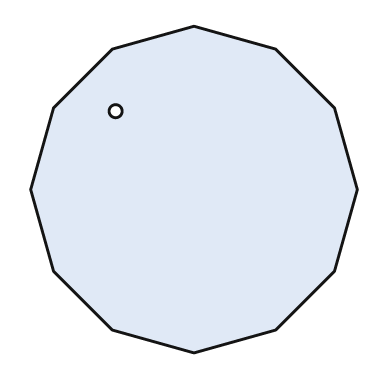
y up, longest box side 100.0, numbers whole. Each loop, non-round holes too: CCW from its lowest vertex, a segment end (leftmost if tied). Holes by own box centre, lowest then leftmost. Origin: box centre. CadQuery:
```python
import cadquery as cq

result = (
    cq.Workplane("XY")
    .moveTo(0.0, -50.0)
    .lineTo(25.0, -43.0)
    .lineTo(43.0, -25.0)
    .lineTo(50.0, 0.0)
    .lineTo(43.0, 25.0)
    .lineTo(25.0, 43.0)
    .lineTo(0.0, 50.0)
    .lineTo(-25.0, 43.0)
    .lineTo(-43.0, 25.0)
    .lineTo(-50.0, 0.0)
    .lineTo(-43.0, -25.0)
    .lineTo(-25.0, -43.0)
    .close()
    .moveTo(-24.0, 24.0)
    .circle(2.0)
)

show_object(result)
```